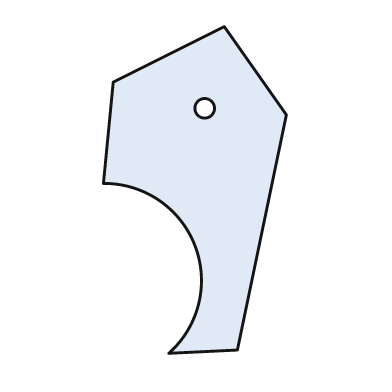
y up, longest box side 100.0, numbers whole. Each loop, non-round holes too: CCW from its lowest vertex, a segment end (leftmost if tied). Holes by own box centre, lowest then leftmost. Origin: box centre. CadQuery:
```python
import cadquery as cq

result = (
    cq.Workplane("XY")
    .moveTo(-8.0, -50.0)
    .lineTo(13.0, -49.0)
    .lineTo(28.0, 23.0)
    .lineTo(9.0, 50.0)
    .lineTo(-25.0, 33.0)
    .lineTo(-28.0, 2.0)
    .threePointArc((0.0, -17.0), (-8.0, -50.0))
    .close()
    .moveTo(3.0, 25.0)
    .circle(3.0)
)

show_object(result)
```